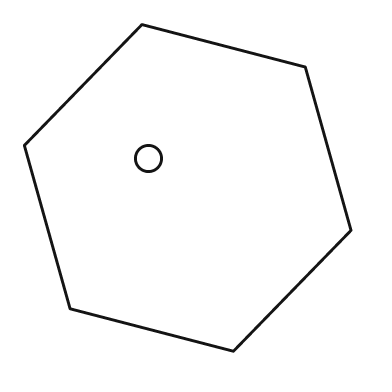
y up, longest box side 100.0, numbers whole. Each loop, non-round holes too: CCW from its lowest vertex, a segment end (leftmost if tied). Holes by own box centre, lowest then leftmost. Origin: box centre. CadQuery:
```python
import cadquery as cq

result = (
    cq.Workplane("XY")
    .moveTo(14.0, -50.0)
    .lineTo(50.0, -13.0)
    .lineTo(36.0, 37.0)
    .lineTo(-14.0, 50.0)
    .lineTo(-50.0, 13.0)
    .lineTo(-36.0, -37.0)
    .close()
    .moveTo(-12.0, 9.0)
    .circle(4.0)
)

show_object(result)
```